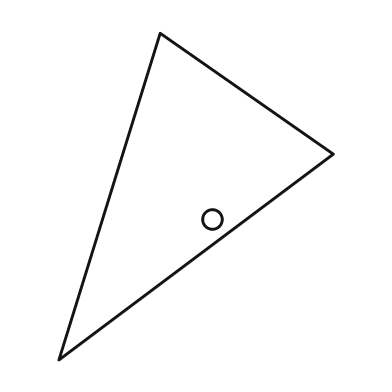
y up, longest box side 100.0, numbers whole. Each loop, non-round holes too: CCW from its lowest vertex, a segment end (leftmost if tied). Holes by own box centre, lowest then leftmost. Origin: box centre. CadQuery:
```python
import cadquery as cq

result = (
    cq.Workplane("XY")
    .moveTo(-42.0, -50.0)
    .lineTo(42.0, 13.0)
    .lineTo(-11.0, 50.0)
    .close()
    .moveTo(5.0, -7.0)
    .circle(3.0)
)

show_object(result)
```